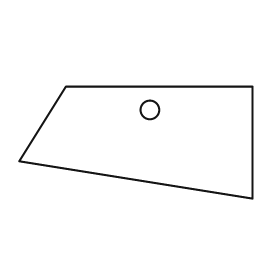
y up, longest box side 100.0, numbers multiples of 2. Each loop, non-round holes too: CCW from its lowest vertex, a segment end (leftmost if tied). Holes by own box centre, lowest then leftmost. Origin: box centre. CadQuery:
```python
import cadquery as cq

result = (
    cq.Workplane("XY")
    .moveTo(50.0, -24.0)
    .lineTo(50.0, 24.0)
    .lineTo(-30.0, 24.0)
    .lineTo(-50.0, -8.0)
    .close()
    .moveTo(6.0, 14.0)
    .circle(4.0)
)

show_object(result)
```